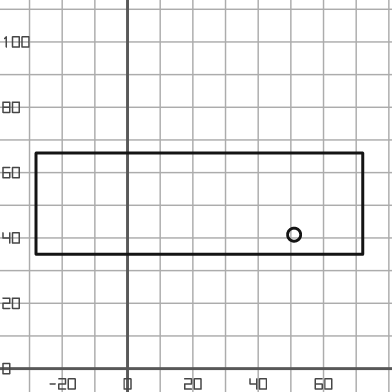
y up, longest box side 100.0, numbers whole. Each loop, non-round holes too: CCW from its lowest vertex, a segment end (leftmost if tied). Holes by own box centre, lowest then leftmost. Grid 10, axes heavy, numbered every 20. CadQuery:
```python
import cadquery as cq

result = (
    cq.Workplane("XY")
    .moveTo(-28.0, 35.0)
    .lineTo(72.0, 35.0)
    .lineTo(72.0, 66.0)
    .lineTo(-28.0, 66.0)
    .close()
    .moveTo(51.0, 41.0)
    .circle(2.0)
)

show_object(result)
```